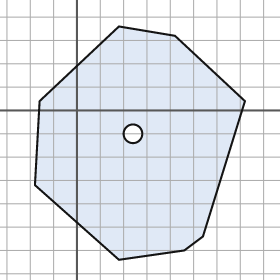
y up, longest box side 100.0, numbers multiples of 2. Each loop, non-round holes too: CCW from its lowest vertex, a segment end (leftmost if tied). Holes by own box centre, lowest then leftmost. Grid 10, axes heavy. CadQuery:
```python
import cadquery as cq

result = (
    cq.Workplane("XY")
    .moveTo(18.0, -64.0)
    .lineTo(46.0, -60.0)
    .lineTo(54.0, -54.0)
    .lineTo(72.0, 4.0)
    .lineTo(42.0, 32.0)
    .lineTo(18.0, 36.0)
    .lineTo(-16.0, 4.0)
    .lineTo(-18.0, -32.0)
    .close()
    .moveTo(24.0, -10.0)
    .circle(4.0)
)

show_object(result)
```